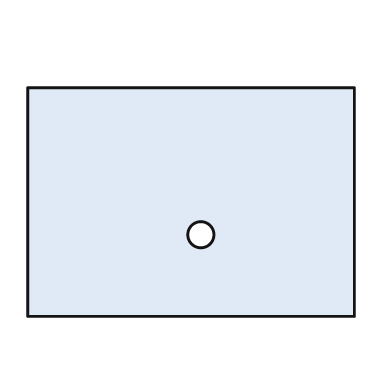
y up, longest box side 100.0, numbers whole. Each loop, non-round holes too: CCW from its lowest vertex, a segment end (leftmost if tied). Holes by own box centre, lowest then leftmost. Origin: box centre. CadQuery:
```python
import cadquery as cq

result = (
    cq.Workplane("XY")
    .moveTo(-50.0, -35.0)
    .lineTo(50.0, -35.0)
    .lineTo(50.0, 35.0)
    .lineTo(-50.0, 35.0)
    .close()
    .moveTo(3.0, -10.0)
    .circle(4.0)
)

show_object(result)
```